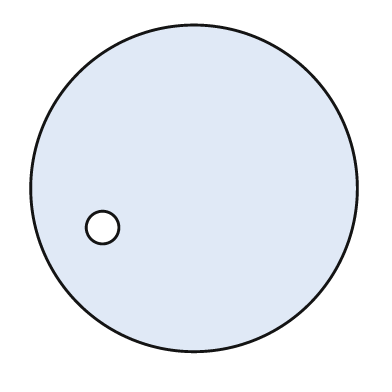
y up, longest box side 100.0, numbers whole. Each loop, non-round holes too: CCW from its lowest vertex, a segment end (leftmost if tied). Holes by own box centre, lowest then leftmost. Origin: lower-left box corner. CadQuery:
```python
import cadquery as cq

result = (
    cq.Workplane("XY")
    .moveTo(50.0, 50.0)
    .circle(50.0)
    .moveTo(22.0, 38.0)
    .circle(5.0)
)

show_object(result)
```